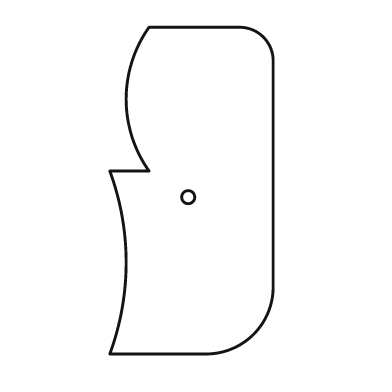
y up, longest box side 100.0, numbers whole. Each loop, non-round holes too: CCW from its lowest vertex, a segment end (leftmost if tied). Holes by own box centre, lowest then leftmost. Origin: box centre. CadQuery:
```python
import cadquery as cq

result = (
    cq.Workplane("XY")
    .moveTo(-25.0, -50.0)
    .lineTo(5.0, -50.0)
    .threePointArc((19.0, -44.0), (25.0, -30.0))
    .lineTo(25.0, 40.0)
    .threePointArc((22.0, 47.0), (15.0, 50.0))
    .lineTo(-13.0, 50.0)
    .threePointArc((-20.0, 28.0), (-13.0, 6.0))
    .lineTo(-25.0, 6.0)
    .threePointArc((-20.0, -22.0), (-25.0, -50.0))
    .close()
    .moveTo(-1.0, -2.0)
    .circle(2.0)
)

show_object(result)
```